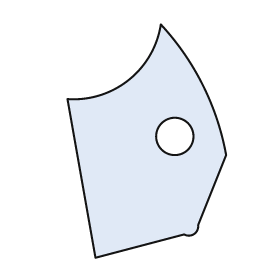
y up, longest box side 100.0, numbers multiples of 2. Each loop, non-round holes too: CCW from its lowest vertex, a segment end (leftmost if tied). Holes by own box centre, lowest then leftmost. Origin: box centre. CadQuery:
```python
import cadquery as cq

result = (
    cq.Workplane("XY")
    .moveTo(-22.0, -50.0)
    .lineTo(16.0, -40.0)
    .threePointArc((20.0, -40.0), (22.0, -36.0))
    .lineTo(34.0, -6.0)
    .threePointArc((24.0, 24.0), (6.0, 50.0))
    .threePointArc((-8.0, 26.0), (-34.0, 18.0))
    .close()
    .moveTo(12.0, 2.0)
    .circle(8.0)
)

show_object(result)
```